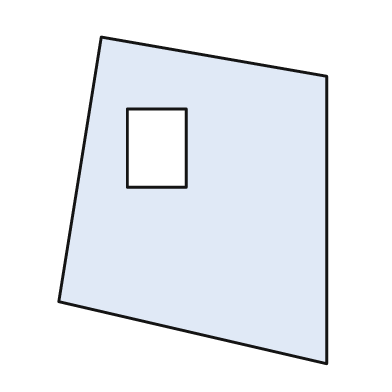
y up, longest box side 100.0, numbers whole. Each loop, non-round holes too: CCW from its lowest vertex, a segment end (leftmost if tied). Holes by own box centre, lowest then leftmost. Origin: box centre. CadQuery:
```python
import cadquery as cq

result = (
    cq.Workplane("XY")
    .moveTo(41.0, -50.0)
    .lineTo(41.0, 38.0)
    .lineTo(-28.0, 50.0)
    .lineTo(-41.0, -31.0)
    .close()
    .moveTo(-20.0, 4.0)
    .lineTo(-2.0, 4.0)
    .lineTo(-2.0, 28.0)
    .lineTo(-20.0, 28.0)
    .close()
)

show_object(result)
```